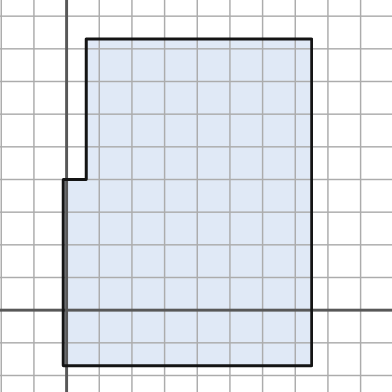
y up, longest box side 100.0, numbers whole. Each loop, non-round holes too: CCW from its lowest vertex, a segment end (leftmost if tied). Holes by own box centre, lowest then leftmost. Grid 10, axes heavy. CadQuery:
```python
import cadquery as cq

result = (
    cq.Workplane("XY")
    .moveTo(-1.0, -17.0)
    .lineTo(75.0, -17.0)
    .lineTo(75.0, 83.0)
    .lineTo(6.0, 83.0)
    .lineTo(6.0, 40.0)
    .lineTo(-1.0, 40.0)
    .close()
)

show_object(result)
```